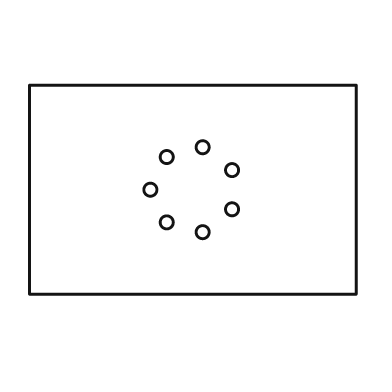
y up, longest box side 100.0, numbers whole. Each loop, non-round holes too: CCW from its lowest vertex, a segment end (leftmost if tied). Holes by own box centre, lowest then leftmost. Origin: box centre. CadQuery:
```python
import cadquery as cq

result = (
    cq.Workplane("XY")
    .moveTo(-50.0, -32.0)
    .lineTo(50.0, -32.0)
    .lineTo(50.0, 32.0)
    .lineTo(-50.0, 32.0)
    .close()
    .moveTo(3.0, -13.0)
    .circle(2.0)
    .moveTo(-8.0, -10.0)
    .circle(2.0)
    .moveTo(12.0, -6.0)
    .circle(2.0)
    .moveTo(-13.0, 0.0)
    .circle(2.0)
    .moveTo(12.0, 6.0)
    .circle(2.0)
    .moveTo(-8.0, 10.0)
    .circle(2.0)
    .moveTo(3.0, 13.0)
    .circle(2.0)
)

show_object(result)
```